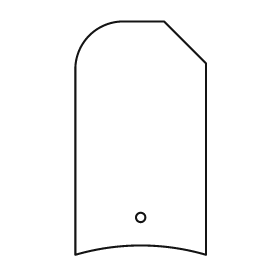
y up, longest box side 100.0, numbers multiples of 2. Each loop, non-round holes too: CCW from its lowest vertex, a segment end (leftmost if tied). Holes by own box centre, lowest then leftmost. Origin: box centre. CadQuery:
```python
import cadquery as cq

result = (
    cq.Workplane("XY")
    .moveTo(-28.0, -50.0)
    .threePointArc((0.0, -46.0), (28.0, -50.0))
    .lineTo(28.0, 32.0)
    .lineTo(10.0, 50.0)
    .lineTo(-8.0, 50.0)
    .threePointArc((-22.0, 44.0), (-28.0, 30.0))
    .close()
    .moveTo(0.0, -34.0)
    .circle(2.0)
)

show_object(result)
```